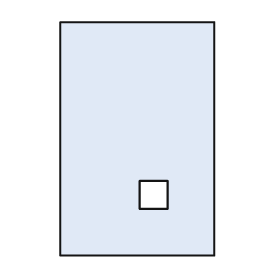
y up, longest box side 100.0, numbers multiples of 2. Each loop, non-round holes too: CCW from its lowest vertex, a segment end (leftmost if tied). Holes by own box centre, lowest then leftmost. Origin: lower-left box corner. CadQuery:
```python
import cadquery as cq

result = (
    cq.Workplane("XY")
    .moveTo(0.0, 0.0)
    .lineTo(66.0, 0.0)
    .lineTo(66.0, 100.0)
    .lineTo(0.0, 100.0)
    .close()
    .moveTo(34.0, 20.0)
    .lineTo(46.0, 20.0)
    .lineTo(46.0, 32.0)
    .lineTo(34.0, 32.0)
    .close()
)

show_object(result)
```